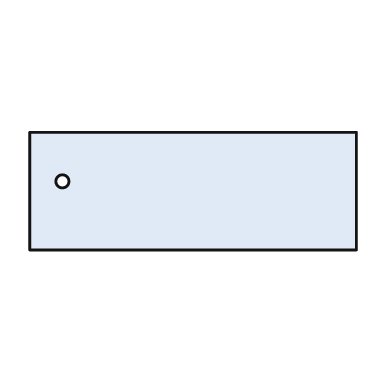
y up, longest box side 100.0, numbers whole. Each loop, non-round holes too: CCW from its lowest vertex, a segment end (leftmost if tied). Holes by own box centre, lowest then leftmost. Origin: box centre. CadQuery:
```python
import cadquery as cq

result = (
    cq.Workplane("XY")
    .moveTo(-50.0, -18.0)
    .lineTo(50.0, -18.0)
    .lineTo(50.0, 18.0)
    .lineTo(-50.0, 18.0)
    .close()
    .moveTo(-40.0, 3.0)
    .circle(2.0)
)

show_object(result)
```